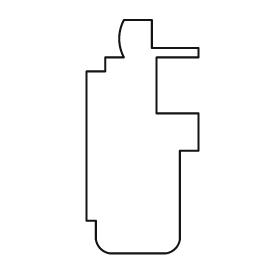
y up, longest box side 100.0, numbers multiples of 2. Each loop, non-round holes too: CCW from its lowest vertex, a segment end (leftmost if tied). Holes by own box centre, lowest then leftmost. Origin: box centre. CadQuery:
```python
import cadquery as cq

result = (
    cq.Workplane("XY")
    .moveTo(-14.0, -50.0)
    .lineTo(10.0, -50.0)
    .threePointArc((14.0, -48.0), (16.0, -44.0))
    .lineTo(16.0, -6.0)
    .lineTo(24.0, -6.0)
    .lineTo(24.0, 10.0)
    .lineTo(6.0, 10.0)
    .lineTo(6.0, 34.0)
    .lineTo(24.0, 34.0)
    .lineTo(24.0, 38.0)
    .lineTo(4.0, 38.0)
    .lineTo(4.0, 50.0)
    .lineTo(-8.0, 50.0)
    .threePointArc((-10.0, 42.0), (-8.0, 34.0))
    .lineTo(-16.0, 34.0)
    .lineTo(-16.0, 28.0)
    .lineTo(-24.0, 28.0)
    .lineTo(-24.0, -36.0)
    .lineTo(-20.0, -36.0)
    .lineTo(-20.0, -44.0)
    .threePointArc((-18.0, -48.0), (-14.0, -50.0))
    .close()
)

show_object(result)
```